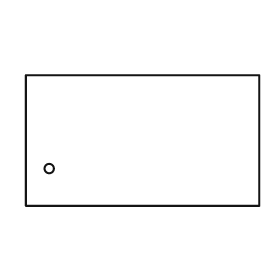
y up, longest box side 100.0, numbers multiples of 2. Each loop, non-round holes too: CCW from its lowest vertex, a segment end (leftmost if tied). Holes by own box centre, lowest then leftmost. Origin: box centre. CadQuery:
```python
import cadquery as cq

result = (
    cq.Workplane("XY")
    .moveTo(-50.0, -28.0)
    .lineTo(50.0, -28.0)
    .lineTo(50.0, 28.0)
    .lineTo(-50.0, 28.0)
    .close()
    .moveTo(-40.0, -12.0)
    .circle(2.0)
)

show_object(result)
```